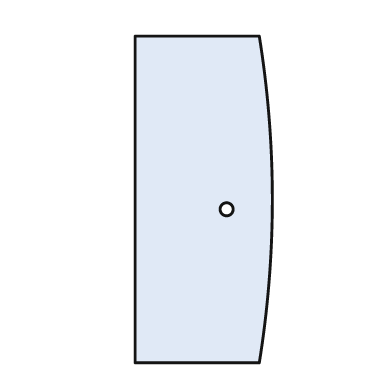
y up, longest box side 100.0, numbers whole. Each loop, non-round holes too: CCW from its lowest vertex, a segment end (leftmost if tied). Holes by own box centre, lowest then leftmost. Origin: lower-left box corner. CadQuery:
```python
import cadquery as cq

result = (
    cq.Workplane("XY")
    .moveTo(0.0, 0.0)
    .lineTo(38.0, 0.0)
    .threePointArc((42.0, 50.0), (38.0, 100.0))
    .lineTo(0.0, 100.0)
    .close()
    .moveTo(28.0, 47.0)
    .circle(2.0)
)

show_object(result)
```